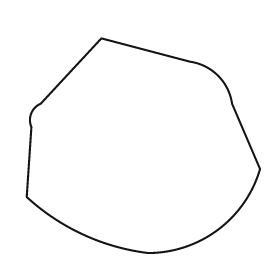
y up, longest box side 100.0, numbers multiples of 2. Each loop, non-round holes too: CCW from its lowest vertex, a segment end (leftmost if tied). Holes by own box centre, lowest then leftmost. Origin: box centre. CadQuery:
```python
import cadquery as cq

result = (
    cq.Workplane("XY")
    .moveTo(2.0, -46.0)
    .threePointArc((32.0, -36.0), (50.0, -10.0))
    .lineTo(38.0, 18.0)
    .threePointArc((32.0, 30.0), (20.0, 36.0))
    .lineTo(-18.0, 46.0)
    .lineTo(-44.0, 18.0)
    .threePointArc((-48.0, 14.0), (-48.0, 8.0))
    .lineTo(-50.0, -22.0)
    .threePointArc((-26.0, -38.0), (2.0, -46.0))
    .close()
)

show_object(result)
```